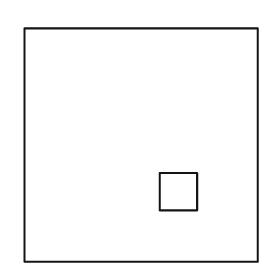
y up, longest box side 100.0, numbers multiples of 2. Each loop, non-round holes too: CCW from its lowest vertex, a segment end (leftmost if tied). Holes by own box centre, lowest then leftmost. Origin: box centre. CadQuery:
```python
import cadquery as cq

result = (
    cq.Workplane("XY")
    .moveTo(-50.0, -50.0)
    .lineTo(50.0, -50.0)
    .lineTo(50.0, 50.0)
    .lineTo(-50.0, 50.0)
    .close()
    .moveTo(8.0, -28.0)
    .lineTo(24.0, -28.0)
    .lineTo(24.0, -12.0)
    .lineTo(8.0, -12.0)
    .close()
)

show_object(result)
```